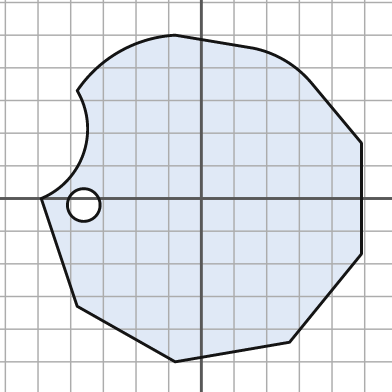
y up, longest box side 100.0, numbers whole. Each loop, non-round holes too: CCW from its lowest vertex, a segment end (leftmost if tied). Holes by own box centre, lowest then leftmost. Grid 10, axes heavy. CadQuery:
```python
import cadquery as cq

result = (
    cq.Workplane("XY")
    .moveTo(-8.0, -50.0)
    .lineTo(27.0, -44.0)
    .lineTo(49.0, -17.0)
    .lineTo(49.0, 17.0)
    .lineTo(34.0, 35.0)
    .threePointArc((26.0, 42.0), (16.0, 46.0))
    .lineTo(-8.0, 50.0)
    .threePointArc((-25.0, 45.0), (-38.0, 33.0))
    .threePointArc((-36.0, 14.0), (-49.0, 0.0))
    .lineTo(-38.0, -33.0)
    .close()
    .moveTo(-36.0, -2.0)
    .circle(5.0)
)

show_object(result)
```